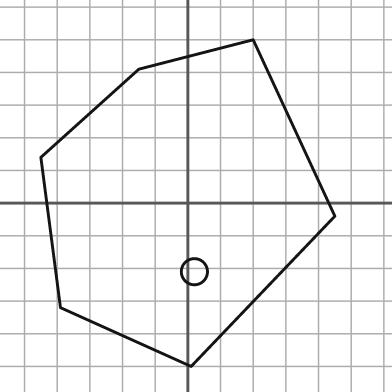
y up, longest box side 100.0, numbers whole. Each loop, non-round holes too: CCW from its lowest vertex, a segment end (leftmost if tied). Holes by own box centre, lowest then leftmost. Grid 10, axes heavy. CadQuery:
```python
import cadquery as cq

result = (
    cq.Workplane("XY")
    .moveTo(1.0, -50.0)
    .lineTo(45.0, -4.0)
    .lineTo(20.0, 50.0)
    .lineTo(-15.0, 41.0)
    .lineTo(-45.0, 14.0)
    .lineTo(-39.0, -32.0)
    .close()
    .moveTo(2.0, -21.0)
    .circle(4.0)
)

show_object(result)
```